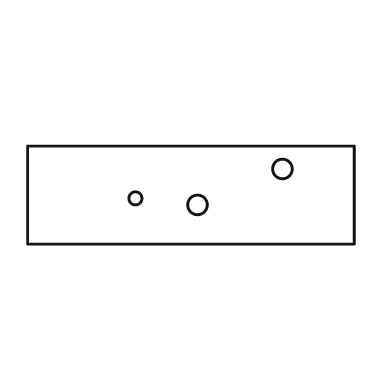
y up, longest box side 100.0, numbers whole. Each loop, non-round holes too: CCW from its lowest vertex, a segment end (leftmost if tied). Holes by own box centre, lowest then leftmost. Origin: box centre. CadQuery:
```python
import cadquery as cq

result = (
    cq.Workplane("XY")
    .moveTo(-50.0, -15.0)
    .lineTo(50.0, -15.0)
    .lineTo(50.0, 15.0)
    .lineTo(-50.0, 15.0)
    .close()
    .moveTo(2.0, -3.0)
    .circle(3.0)
    .moveTo(-17.0, -1.0)
    .circle(2.0)
    .moveTo(28.0, 8.0)
    .circle(3.0)
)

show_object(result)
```